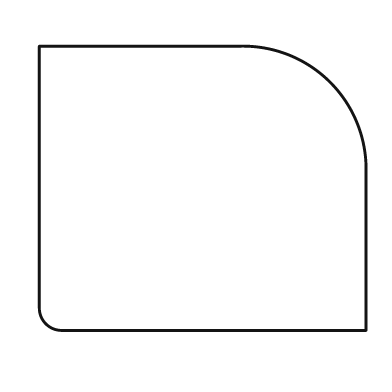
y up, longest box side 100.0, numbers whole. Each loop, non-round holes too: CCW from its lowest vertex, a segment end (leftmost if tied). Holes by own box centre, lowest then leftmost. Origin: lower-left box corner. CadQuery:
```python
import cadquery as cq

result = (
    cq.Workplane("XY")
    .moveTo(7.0, 0.0)
    .lineTo(100.0, 0.0)
    .lineTo(100.0, 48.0)
    .threePointArc((89.0, 76.0), (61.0, 87.0))
    .lineTo(0.0, 87.0)
    .lineTo(0.0, 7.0)
    .threePointArc((2.0, 2.0), (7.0, 0.0))
    .close()
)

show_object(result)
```